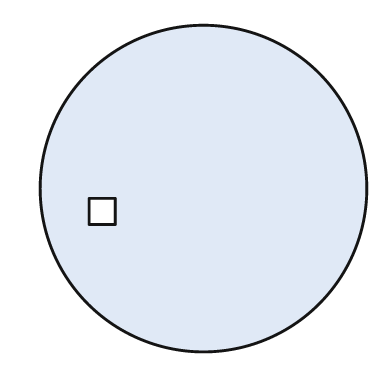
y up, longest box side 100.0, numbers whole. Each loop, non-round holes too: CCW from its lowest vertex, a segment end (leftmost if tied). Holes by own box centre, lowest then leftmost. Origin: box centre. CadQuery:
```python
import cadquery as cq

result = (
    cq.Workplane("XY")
    .moveTo(0.0, 0.0)
    .circle(50.0)
    .moveTo(-35.0, -11.0)
    .lineTo(-27.0, -11.0)
    .lineTo(-27.0, -3.0)
    .lineTo(-35.0, -3.0)
    .close()
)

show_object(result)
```